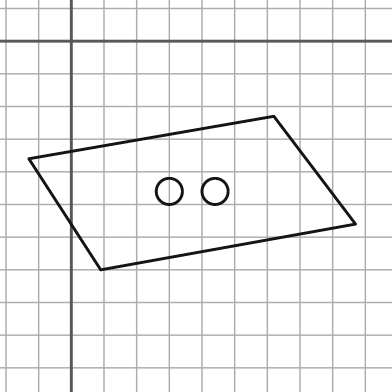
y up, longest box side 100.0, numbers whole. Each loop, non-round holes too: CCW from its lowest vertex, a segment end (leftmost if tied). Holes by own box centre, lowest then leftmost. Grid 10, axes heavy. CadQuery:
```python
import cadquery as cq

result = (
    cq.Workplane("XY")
    .moveTo(9.0, -70.0)
    .lineTo(87.0, -56.0)
    .lineTo(62.0, -23.0)
    .lineTo(-13.0, -36.0)
    .close()
    .moveTo(30.0, -46.0)
    .circle(4.0)
    .moveTo(44.0, -46.0)
    .circle(4.0)
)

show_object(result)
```